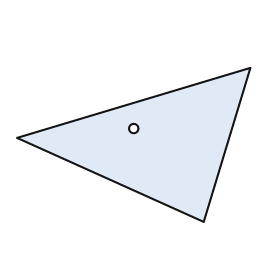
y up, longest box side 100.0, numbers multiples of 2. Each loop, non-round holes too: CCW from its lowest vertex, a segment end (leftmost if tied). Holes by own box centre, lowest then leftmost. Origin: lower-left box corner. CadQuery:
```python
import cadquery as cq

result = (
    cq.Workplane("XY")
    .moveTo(80.0, 0.0)
    .lineTo(100.0, 66.0)
    .lineTo(0.0, 36.0)
    .close()
    .moveTo(50.0, 40.0)
    .circle(2.0)
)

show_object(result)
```